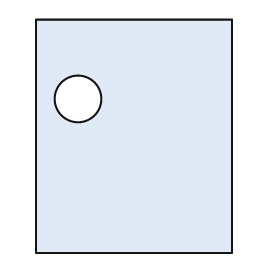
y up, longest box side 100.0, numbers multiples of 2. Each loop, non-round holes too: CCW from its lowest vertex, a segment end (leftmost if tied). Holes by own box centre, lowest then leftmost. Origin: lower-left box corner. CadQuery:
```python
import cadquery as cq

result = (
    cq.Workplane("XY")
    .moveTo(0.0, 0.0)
    .lineTo(84.0, 0.0)
    .lineTo(84.0, 100.0)
    .lineTo(0.0, 100.0)
    .close()
    .moveTo(18.0, 66.0)
    .circle(10.0)
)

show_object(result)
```